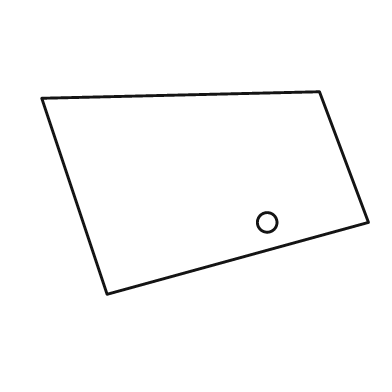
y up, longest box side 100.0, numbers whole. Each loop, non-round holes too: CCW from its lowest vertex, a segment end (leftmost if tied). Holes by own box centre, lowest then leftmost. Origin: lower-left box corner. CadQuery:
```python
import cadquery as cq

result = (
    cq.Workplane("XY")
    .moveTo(20.0, 0.0)
    .lineTo(100.0, 22.0)
    .lineTo(85.0, 62.0)
    .lineTo(0.0, 60.0)
    .close()
    .moveTo(69.0, 22.0)
    .circle(3.0)
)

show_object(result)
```